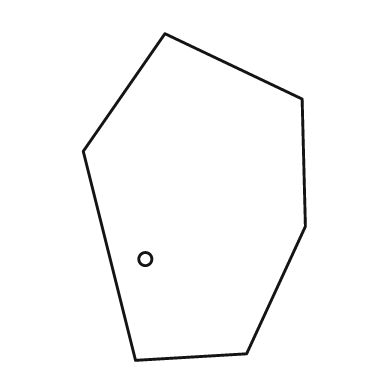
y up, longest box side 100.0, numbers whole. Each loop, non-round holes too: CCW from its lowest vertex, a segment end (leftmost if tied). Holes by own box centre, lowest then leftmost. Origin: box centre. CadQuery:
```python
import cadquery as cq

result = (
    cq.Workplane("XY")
    .moveTo(-18.0, -50.0)
    .lineTo(16.0, -48.0)
    .lineTo(34.0, -9.0)
    .lineTo(33.0, 30.0)
    .lineTo(-9.0, 50.0)
    .lineTo(-34.0, 14.0)
    .close()
    .moveTo(-15.0, -19.0)
    .circle(2.0)
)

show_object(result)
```